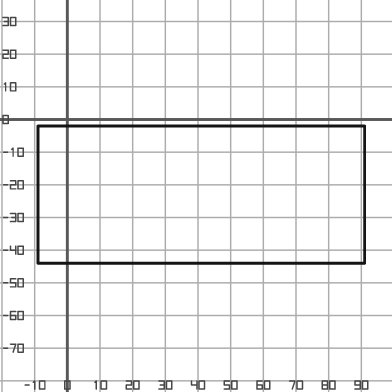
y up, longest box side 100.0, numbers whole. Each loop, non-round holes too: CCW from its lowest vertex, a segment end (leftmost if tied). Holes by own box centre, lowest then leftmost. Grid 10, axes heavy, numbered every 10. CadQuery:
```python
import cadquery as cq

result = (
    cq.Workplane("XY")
    .moveTo(-9.0, -44.0)
    .lineTo(91.0, -44.0)
    .lineTo(91.0, -2.0)
    .lineTo(-9.0, -2.0)
    .close()
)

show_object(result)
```